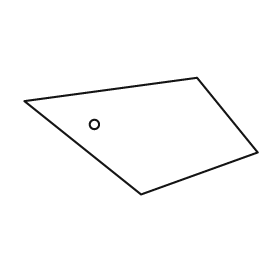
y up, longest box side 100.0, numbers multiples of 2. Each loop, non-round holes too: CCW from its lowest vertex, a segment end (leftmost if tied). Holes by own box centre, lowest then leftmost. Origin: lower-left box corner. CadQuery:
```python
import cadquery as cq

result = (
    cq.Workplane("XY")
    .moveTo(50.0, 0.0)
    .lineTo(100.0, 18.0)
    .lineTo(74.0, 50.0)
    .lineTo(0.0, 40.0)
    .close()
    .moveTo(30.0, 30.0)
    .circle(2.0)
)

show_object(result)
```